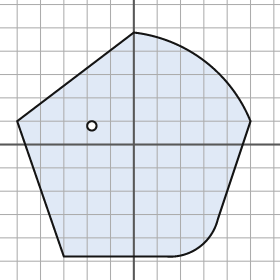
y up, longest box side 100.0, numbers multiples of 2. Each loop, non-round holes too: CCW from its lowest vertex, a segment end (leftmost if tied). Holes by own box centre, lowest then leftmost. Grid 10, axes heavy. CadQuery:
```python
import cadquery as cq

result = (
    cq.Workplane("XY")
    .moveTo(-30.0, -48.0)
    .lineTo(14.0, -48.0)
    .threePointArc((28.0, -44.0), (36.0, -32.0))
    .lineTo(50.0, 10.0)
    .threePointArc((30.0, 36.0), (0.0, 48.0))
    .lineTo(-50.0, 10.0)
    .close()
    .moveTo(-18.0, 8.0)
    .circle(2.0)
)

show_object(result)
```